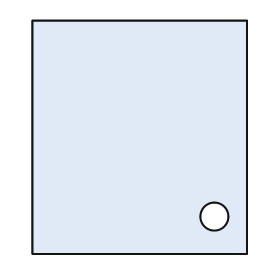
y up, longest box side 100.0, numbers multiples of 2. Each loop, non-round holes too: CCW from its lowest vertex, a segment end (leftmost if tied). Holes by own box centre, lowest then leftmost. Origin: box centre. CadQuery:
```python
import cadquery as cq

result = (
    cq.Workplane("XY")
    .moveTo(-46.0, -50.0)
    .lineTo(46.0, -50.0)
    .lineTo(46.0, 50.0)
    .lineTo(-46.0, 50.0)
    .close()
    .moveTo(32.0, -34.0)
    .circle(6.0)
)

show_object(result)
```